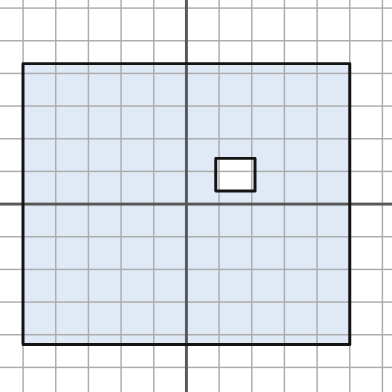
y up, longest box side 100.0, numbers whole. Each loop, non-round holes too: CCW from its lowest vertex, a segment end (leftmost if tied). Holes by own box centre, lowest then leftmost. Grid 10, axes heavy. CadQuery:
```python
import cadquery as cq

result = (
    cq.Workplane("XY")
    .moveTo(-50.0, -43.0)
    .lineTo(50.0, -43.0)
    .lineTo(50.0, 43.0)
    .lineTo(-50.0, 43.0)
    .close()
    .moveTo(9.0, 4.0)
    .lineTo(21.0, 4.0)
    .lineTo(21.0, 14.0)
    .lineTo(9.0, 14.0)
    .close()
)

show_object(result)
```